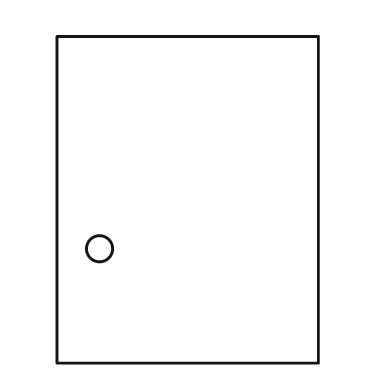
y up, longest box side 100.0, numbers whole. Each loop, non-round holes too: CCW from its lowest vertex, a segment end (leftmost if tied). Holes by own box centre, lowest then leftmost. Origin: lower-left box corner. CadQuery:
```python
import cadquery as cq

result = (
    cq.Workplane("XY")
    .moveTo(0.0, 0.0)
    .lineTo(80.0, 0.0)
    .lineTo(80.0, 100.0)
    .lineTo(0.0, 100.0)
    .close()
    .moveTo(13.0, 35.0)
    .circle(4.0)
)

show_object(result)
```